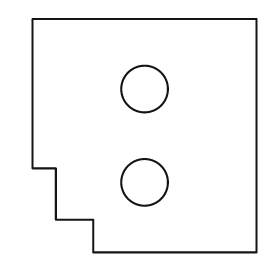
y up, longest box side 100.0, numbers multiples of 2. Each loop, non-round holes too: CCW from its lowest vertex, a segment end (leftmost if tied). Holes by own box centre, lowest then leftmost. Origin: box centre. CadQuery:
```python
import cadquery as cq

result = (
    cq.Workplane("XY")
    .moveTo(-22.0, -50.0)
    .lineTo(48.0, -50.0)
    .lineTo(48.0, 50.0)
    .lineTo(-48.0, 50.0)
    .lineTo(-48.0, -14.0)
    .lineTo(-38.0, -14.0)
    .lineTo(-38.0, -36.0)
    .lineTo(-22.0, -36.0)
    .close()
    .moveTo(0.0, -20.0)
    .circle(10.0)
    .moveTo(0.0, 20.0)
    .circle(10.0)
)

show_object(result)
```